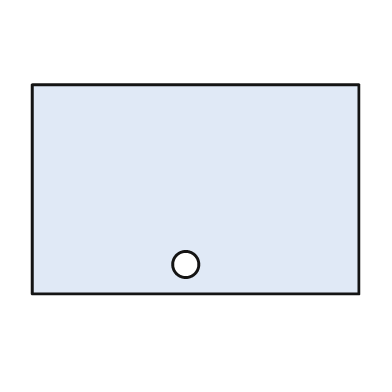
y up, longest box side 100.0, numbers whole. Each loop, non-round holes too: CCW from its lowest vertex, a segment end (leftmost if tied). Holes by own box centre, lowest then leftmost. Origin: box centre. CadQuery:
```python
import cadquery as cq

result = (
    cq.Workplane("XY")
    .moveTo(-50.0, -32.0)
    .lineTo(50.0, -32.0)
    .lineTo(50.0, 32.0)
    .lineTo(-50.0, 32.0)
    .close()
    .moveTo(-3.0, -23.0)
    .circle(4.0)
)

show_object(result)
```